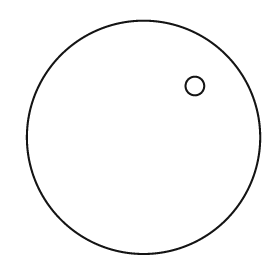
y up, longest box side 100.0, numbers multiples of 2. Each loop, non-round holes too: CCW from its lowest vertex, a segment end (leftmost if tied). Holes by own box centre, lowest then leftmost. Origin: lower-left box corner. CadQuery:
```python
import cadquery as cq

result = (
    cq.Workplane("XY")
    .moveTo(50.0, 50.0)
    .circle(50.0)
    .moveTo(72.0, 72.0)
    .circle(4.0)
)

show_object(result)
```